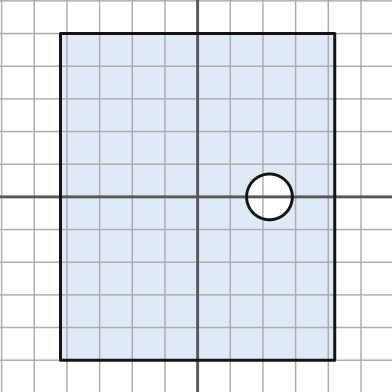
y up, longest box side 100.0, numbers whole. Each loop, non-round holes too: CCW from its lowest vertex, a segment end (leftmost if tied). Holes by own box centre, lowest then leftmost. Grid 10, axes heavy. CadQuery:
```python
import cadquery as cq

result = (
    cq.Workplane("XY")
    .moveTo(-42.0, -50.0)
    .lineTo(42.0, -50.0)
    .lineTo(42.0, 50.0)
    .lineTo(-42.0, 50.0)
    .close()
    .moveTo(22.0, 0.0)
    .circle(7.0)
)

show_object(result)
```